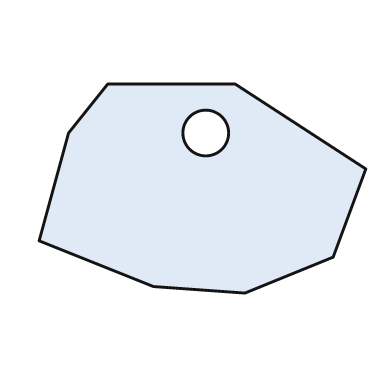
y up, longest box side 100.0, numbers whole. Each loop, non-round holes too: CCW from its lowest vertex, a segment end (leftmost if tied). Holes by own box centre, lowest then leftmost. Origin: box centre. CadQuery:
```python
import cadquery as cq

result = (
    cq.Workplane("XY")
    .moveTo(13.0, -32.0)
    .lineTo(40.0, -21.0)
    .lineTo(50.0, 6.0)
    .lineTo(10.0, 32.0)
    .lineTo(-29.0, 32.0)
    .lineTo(-41.0, 17.0)
    .lineTo(-50.0, -16.0)
    .lineTo(-15.0, -30.0)
    .close()
    .moveTo(1.0, 17.0)
    .circle(7.0)
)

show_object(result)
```